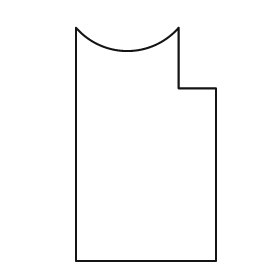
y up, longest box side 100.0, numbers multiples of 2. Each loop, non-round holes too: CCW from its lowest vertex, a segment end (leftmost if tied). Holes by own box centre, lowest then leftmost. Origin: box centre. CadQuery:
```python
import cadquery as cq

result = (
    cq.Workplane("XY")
    .moveTo(-30.0, -50.0)
    .lineTo(30.0, -50.0)
    .lineTo(30.0, 24.0)
    .lineTo(14.0, 24.0)
    .lineTo(14.0, 50.0)
    .threePointArc((-8.0, 40.0), (-30.0, 50.0))
    .close()
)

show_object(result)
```